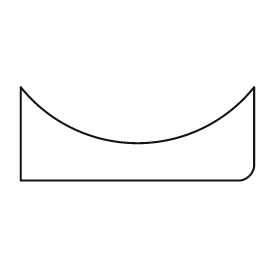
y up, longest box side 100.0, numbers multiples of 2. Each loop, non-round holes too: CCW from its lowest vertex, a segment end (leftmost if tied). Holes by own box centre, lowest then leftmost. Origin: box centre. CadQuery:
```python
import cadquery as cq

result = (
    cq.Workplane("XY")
    .moveTo(-50.0, -20.0)
    .lineTo(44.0, -20.0)
    .threePointArc((48.0, -18.0), (50.0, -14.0))
    .lineTo(50.0, 20.0)
    .threePointArc((0.0, -4.0), (-50.0, 20.0))
    .close()
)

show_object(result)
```